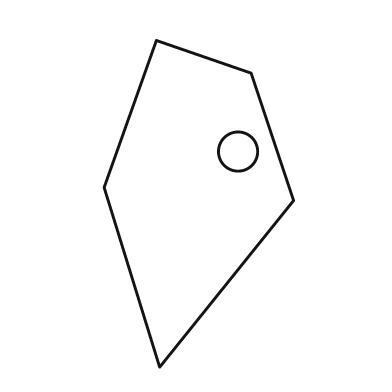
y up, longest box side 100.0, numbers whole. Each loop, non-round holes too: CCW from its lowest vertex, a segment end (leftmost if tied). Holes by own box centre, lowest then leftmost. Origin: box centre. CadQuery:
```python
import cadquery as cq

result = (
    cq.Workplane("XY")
    .moveTo(-12.0, -50.0)
    .lineTo(29.0, 1.0)
    .lineTo(16.0, 40.0)
    .lineTo(-13.0, 50.0)
    .lineTo(-29.0, 5.0)
    .close()
    .moveTo(12.0, 16.0)
    .circle(6.0)
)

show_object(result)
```